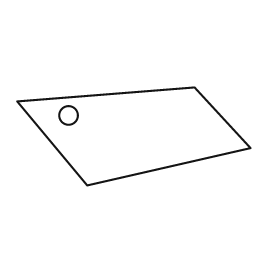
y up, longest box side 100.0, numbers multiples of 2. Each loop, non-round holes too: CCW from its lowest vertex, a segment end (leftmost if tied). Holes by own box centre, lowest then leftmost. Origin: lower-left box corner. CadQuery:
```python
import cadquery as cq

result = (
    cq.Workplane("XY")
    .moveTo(30.0, 0.0)
    .lineTo(100.0, 16.0)
    .lineTo(76.0, 42.0)
    .lineTo(0.0, 36.0)
    .close()
    .moveTo(22.0, 30.0)
    .circle(4.0)
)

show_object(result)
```